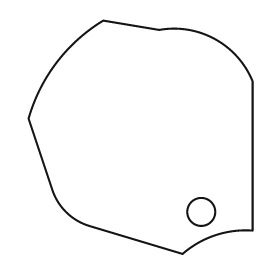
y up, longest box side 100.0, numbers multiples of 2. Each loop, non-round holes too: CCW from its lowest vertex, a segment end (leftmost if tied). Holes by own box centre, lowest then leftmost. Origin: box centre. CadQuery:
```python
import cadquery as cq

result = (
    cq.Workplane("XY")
    .moveTo(18.0, -50.0)
    .threePointArc((32.0, -42.0), (48.0, -40.0))
    .lineTo(48.0, 24.0)
    .threePointArc((32.0, 42.0), (8.0, 46.0))
    .lineTo(-16.0, 50.0)
    .threePointArc((-36.0, 32.0), (-48.0, 8.0))
    .lineTo(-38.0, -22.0)
    .threePointArc((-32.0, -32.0), (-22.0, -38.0))
    .close()
    .moveTo(26.0, -32.0)
    .circle(6.0)
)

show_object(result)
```